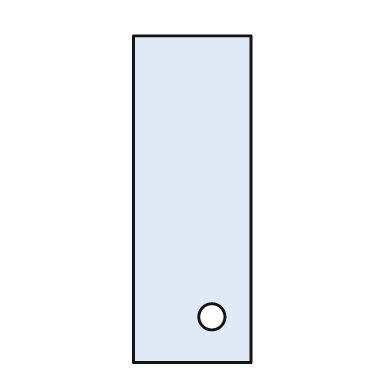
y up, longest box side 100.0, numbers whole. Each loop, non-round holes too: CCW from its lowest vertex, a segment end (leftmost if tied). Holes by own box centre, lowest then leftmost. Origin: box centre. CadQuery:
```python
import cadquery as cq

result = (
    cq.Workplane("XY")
    .moveTo(-18.0, -50.0)
    .lineTo(18.0, -50.0)
    .lineTo(18.0, 50.0)
    .lineTo(-18.0, 50.0)
    .close()
    .moveTo(6.0, -36.0)
    .circle(4.0)
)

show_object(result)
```